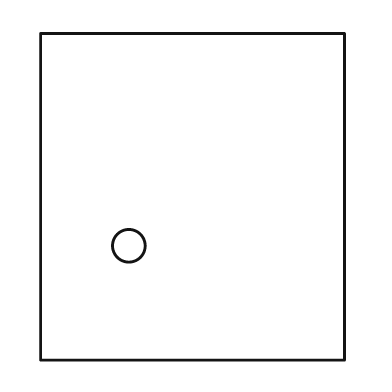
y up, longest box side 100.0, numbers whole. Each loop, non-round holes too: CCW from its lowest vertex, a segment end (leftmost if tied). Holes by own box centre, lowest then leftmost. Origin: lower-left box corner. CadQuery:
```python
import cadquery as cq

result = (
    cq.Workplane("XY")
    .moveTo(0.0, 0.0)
    .lineTo(93.0, 0.0)
    .lineTo(93.0, 100.0)
    .lineTo(0.0, 100.0)
    .close()
    .moveTo(27.0, 35.0)
    .circle(5.0)
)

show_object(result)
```